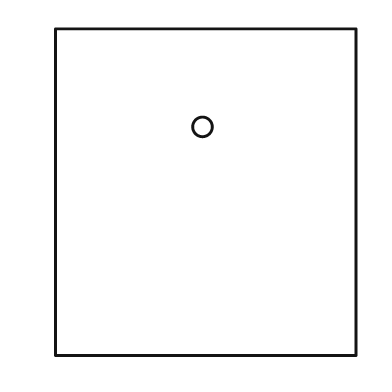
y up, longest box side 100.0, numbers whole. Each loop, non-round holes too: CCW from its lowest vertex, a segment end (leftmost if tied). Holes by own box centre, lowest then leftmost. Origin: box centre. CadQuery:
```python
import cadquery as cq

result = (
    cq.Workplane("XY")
    .moveTo(-46.0, -50.0)
    .lineTo(46.0, -50.0)
    .lineTo(46.0, 50.0)
    .lineTo(-46.0, 50.0)
    .close()
    .moveTo(-1.0, 20.0)
    .circle(3.0)
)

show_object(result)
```